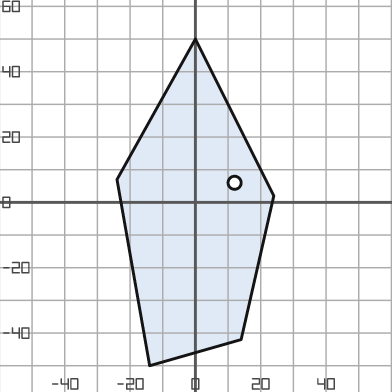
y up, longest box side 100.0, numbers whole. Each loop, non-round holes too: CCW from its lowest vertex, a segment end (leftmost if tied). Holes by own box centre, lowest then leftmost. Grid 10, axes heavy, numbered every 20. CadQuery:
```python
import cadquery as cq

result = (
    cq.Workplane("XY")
    .moveTo(-14.0, -50.0)
    .lineTo(14.0, -42.0)
    .lineTo(24.0, 2.0)
    .lineTo(0.0, 50.0)
    .lineTo(-24.0, 7.0)
    .close()
    .moveTo(12.0, 6.0)
    .circle(2.0)
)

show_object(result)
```